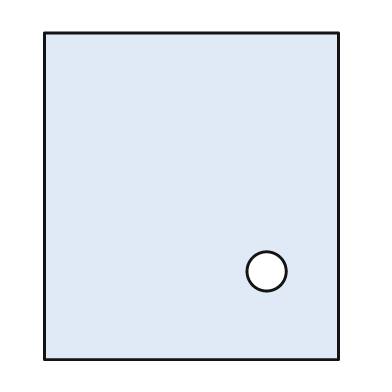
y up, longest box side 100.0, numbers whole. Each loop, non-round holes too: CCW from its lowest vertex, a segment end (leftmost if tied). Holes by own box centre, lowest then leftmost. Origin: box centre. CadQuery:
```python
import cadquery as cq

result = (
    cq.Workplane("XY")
    .moveTo(-45.0, -50.0)
    .lineTo(45.0, -50.0)
    .lineTo(45.0, 50.0)
    .lineTo(-45.0, 50.0)
    .close()
    .moveTo(23.0, -23.0)
    .circle(6.0)
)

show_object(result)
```